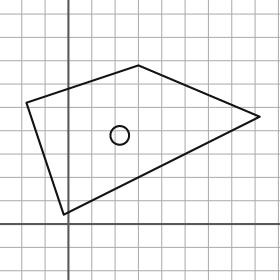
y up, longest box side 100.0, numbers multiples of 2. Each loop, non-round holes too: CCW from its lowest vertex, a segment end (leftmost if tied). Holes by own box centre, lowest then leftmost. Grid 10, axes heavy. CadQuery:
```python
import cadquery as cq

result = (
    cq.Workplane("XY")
    .moveTo(-2.0, 4.0)
    .lineTo(82.0, 46.0)
    .lineTo(30.0, 68.0)
    .lineTo(-18.0, 52.0)
    .close()
    .moveTo(22.0, 38.0)
    .circle(4.0)
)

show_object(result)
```